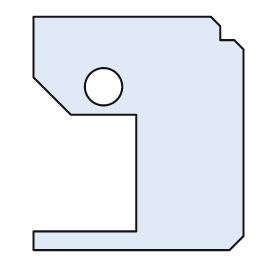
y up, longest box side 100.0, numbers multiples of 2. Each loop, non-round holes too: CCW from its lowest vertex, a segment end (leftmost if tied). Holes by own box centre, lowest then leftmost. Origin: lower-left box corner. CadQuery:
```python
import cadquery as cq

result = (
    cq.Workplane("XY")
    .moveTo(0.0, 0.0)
    .lineTo(84.0, 0.0)
    .lineTo(90.0, 6.0)
    .lineTo(90.0, 86.0)
    .lineTo(86.0, 90.0)
    .lineTo(80.0, 90.0)
    .lineTo(80.0, 96.0)
    .lineTo(76.0, 100.0)
    .lineTo(0.0, 100.0)
    .lineTo(0.0, 74.0)
    .lineTo(16.0, 58.0)
    .lineTo(44.0, 58.0)
    .lineTo(44.0, 8.0)
    .lineTo(0.0, 8.0)
    .close()
    .moveTo(30.0, 70.0)
    .circle(8.0)
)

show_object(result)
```